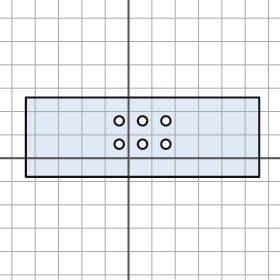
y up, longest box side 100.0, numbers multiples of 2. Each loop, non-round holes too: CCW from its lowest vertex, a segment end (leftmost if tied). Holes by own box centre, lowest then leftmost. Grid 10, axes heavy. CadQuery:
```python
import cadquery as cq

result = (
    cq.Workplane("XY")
    .moveTo(-44.0, -8.0)
    .lineTo(56.0, -8.0)
    .lineTo(56.0, 26.0)
    .lineTo(-44.0, 26.0)
    .close()
    .moveTo(-4.0, 6.0)
    .circle(2.0)
    .moveTo(6.0, 6.0)
    .circle(2.0)
    .moveTo(16.0, 6.0)
    .circle(2.0)
    .moveTo(-4.0, 16.0)
    .circle(2.0)
    .moveTo(6.0, 16.0)
    .circle(2.0)
    .moveTo(16.0, 16.0)
    .circle(2.0)
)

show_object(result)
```